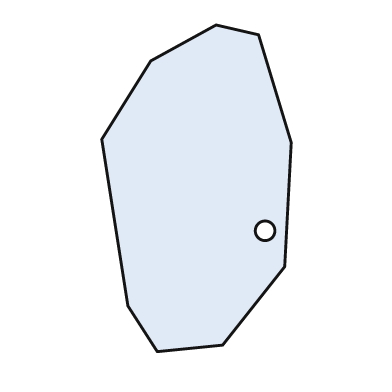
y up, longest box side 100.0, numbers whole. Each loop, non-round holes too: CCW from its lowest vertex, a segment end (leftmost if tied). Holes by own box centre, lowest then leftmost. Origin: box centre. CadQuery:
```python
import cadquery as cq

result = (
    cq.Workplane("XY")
    .moveTo(-12.0, -50.0)
    .lineTo(8.0, -48.0)
    .lineTo(27.0, -24.0)
    .lineTo(29.0, 14.0)
    .lineTo(19.0, 47.0)
    .lineTo(6.0, 50.0)
    .lineTo(-14.0, 39.0)
    .lineTo(-29.0, 15.0)
    .lineTo(-21.0, -36.0)
    .close()
    .moveTo(21.0, -13.0)
    .circle(3.0)
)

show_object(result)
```